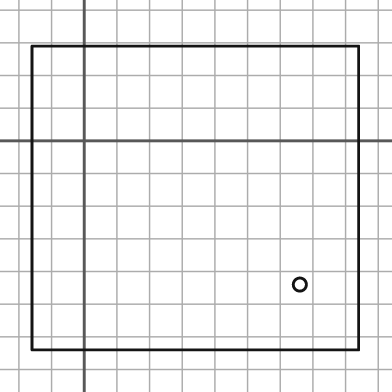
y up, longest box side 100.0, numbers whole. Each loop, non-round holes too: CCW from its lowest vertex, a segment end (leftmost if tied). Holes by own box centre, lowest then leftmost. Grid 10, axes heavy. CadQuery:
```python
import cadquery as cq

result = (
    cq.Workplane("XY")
    .moveTo(-16.0, -64.0)
    .lineTo(84.0, -64.0)
    .lineTo(84.0, 29.0)
    .lineTo(-16.0, 29.0)
    .close()
    .moveTo(66.0, -44.0)
    .circle(2.0)
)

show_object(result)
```